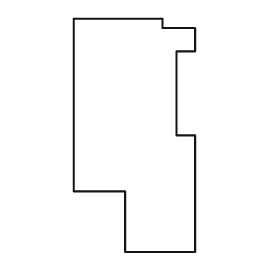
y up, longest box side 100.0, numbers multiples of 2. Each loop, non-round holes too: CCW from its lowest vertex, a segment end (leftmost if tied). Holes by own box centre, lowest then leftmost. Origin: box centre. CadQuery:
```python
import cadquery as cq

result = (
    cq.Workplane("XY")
    .moveTo(-4.0, -50.0)
    .lineTo(26.0, -50.0)
    .lineTo(26.0, 0.0)
    .lineTo(18.0, 0.0)
    .lineTo(18.0, 36.0)
    .lineTo(26.0, 36.0)
    .lineTo(26.0, 46.0)
    .lineTo(12.0, 46.0)
    .lineTo(12.0, 50.0)
    .lineTo(-26.0, 50.0)
    .lineTo(-26.0, -24.0)
    .lineTo(-4.0, -24.0)
    .close()
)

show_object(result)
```